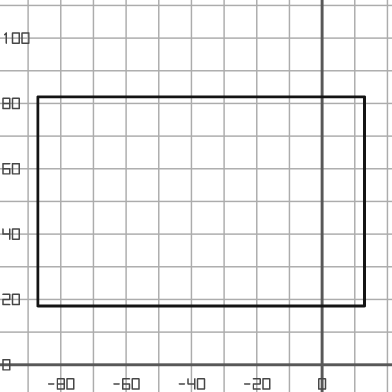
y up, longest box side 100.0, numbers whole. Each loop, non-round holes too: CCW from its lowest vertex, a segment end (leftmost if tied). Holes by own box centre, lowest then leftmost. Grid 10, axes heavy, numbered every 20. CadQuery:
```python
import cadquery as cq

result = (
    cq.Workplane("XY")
    .moveTo(-87.0, 18.0)
    .lineTo(13.0, 18.0)
    .lineTo(13.0, 82.0)
    .lineTo(-87.0, 82.0)
    .close()
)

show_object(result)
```